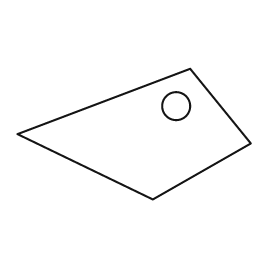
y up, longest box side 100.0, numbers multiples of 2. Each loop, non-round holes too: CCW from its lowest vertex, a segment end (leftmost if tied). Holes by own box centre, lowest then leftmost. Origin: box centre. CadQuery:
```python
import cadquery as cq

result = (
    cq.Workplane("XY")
    .moveTo(8.0, -28.0)
    .lineTo(50.0, -4.0)
    .lineTo(24.0, 28.0)
    .lineTo(-50.0, 0.0)
    .close()
    .moveTo(18.0, 12.0)
    .circle(6.0)
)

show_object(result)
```